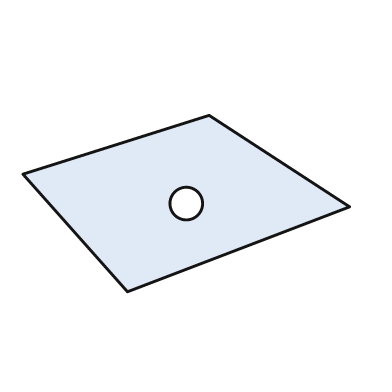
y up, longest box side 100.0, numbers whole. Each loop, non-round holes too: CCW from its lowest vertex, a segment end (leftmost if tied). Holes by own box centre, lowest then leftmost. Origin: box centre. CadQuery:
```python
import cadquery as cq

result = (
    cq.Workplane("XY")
    .moveTo(-18.0, -27.0)
    .lineTo(50.0, -1.0)
    .lineTo(7.0, 27.0)
    .lineTo(-50.0, 9.0)
    .close()
    .moveTo(0.0, 0.0)
    .circle(5.0)
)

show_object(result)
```